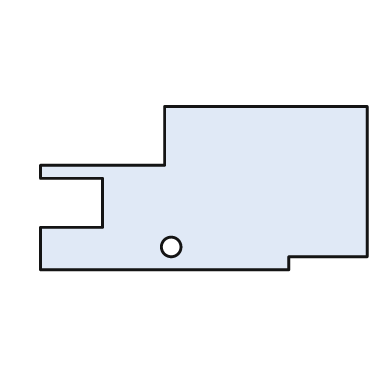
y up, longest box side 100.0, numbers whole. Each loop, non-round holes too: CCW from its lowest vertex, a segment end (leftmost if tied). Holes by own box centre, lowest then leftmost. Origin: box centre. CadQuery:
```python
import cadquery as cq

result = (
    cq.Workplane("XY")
    .moveTo(-50.0, -25.0)
    .lineTo(26.0, -25.0)
    .lineTo(26.0, -21.0)
    .lineTo(50.0, -21.0)
    .lineTo(50.0, 25.0)
    .lineTo(-12.0, 25.0)
    .lineTo(-12.0, 7.0)
    .lineTo(-50.0, 7.0)
    .lineTo(-50.0, 3.0)
    .lineTo(-31.0, 3.0)
    .lineTo(-31.0, -12.0)
    .lineTo(-50.0, -12.0)
    .close()
    .moveTo(-10.0, -18.0)
    .circle(3.0)
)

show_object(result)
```